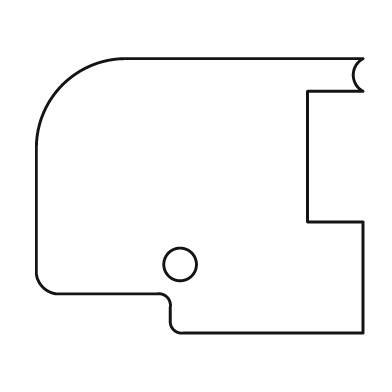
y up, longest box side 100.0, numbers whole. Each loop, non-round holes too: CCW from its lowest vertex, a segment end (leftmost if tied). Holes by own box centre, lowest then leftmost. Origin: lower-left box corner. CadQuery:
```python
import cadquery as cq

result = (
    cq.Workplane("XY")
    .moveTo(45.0, 0.0)
    .lineTo(100.0, 0.0)
    .lineTo(100.0, 34.0)
    .lineTo(83.0, 34.0)
    .lineTo(83.0, 74.0)
    .lineTo(100.0, 74.0)
    .threePointArc((97.0, 79.0), (100.0, 84.0))
    .lineTo(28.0, 84.0)
    .threePointArc((8.0, 76.0), (0.0, 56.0))
    .lineTo(0.0, 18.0)
    .threePointArc((2.0, 14.0), (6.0, 12.0))
    .lineTo(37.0, 12.0)
    .threePointArc((40.0, 11.0), (41.0, 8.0))
    .lineTo(41.0, 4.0)
    .threePointArc((42.0, 1.0), (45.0, 0.0))
    .close()
    .moveTo(44.0, 21.0)
    .circle(5.0)
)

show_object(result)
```